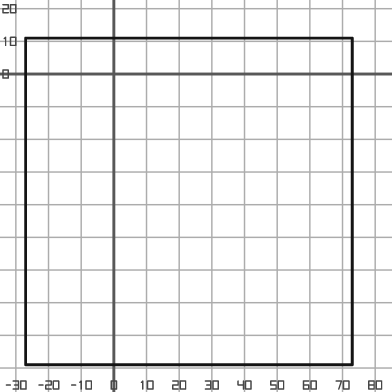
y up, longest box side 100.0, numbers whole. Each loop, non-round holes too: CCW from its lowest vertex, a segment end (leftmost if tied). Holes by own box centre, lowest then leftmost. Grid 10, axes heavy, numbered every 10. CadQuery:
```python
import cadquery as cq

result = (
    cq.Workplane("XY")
    .moveTo(-27.0, -89.0)
    .lineTo(73.0, -89.0)
    .lineTo(73.0, 11.0)
    .lineTo(-27.0, 11.0)
    .close()
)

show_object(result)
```